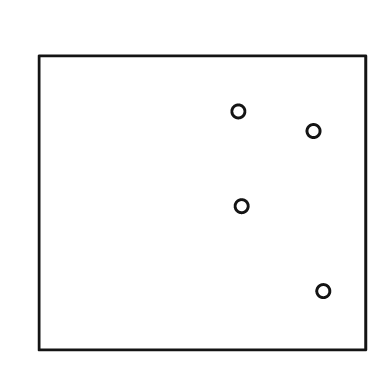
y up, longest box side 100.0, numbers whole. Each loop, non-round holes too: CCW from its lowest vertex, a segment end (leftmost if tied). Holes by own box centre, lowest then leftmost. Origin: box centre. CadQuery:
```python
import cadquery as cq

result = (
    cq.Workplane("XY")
    .moveTo(-50.0, -45.0)
    .lineTo(50.0, -45.0)
    .lineTo(50.0, 45.0)
    .lineTo(-50.0, 45.0)
    .close()
    .moveTo(37.0, -27.0)
    .circle(2.0)
    .moveTo(12.0, -1.0)
    .circle(2.0)
    .moveTo(34.0, 22.0)
    .circle(2.0)
    .moveTo(11.0, 28.0)
    .circle(2.0)
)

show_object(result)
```